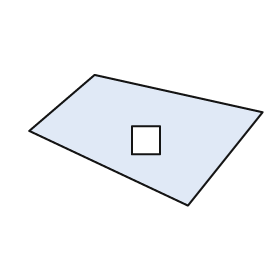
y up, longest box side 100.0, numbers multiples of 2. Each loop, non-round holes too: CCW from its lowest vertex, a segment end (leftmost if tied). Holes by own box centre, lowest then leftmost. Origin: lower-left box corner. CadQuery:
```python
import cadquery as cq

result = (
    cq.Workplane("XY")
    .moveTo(68.0, 0.0)
    .lineTo(100.0, 40.0)
    .lineTo(28.0, 56.0)
    .lineTo(0.0, 32.0)
    .close()
    .moveTo(44.0, 22.0)
    .lineTo(56.0, 22.0)
    .lineTo(56.0, 34.0)
    .lineTo(44.0, 34.0)
    .close()
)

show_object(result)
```